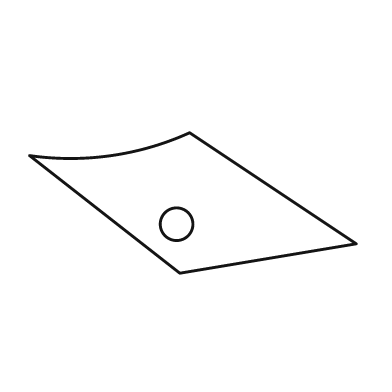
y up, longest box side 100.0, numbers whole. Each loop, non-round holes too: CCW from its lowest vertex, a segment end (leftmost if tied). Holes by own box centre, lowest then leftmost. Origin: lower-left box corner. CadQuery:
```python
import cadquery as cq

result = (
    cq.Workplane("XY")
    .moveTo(46.0, 0.0)
    .lineTo(100.0, 9.0)
    .lineTo(49.0, 43.0)
    .threePointArc((25.0, 36.0), (0.0, 36.0))
    .close()
    .moveTo(45.0, 15.0)
    .circle(5.0)
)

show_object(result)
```